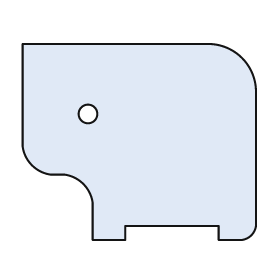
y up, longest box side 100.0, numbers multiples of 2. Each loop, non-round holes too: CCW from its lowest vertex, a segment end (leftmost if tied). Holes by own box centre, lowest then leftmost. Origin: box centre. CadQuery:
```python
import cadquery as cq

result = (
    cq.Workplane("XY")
    .moveTo(-20.0, -42.0)
    .lineTo(-6.0, -42.0)
    .lineTo(-6.0, -36.0)
    .lineTo(34.0, -36.0)
    .lineTo(34.0, -42.0)
    .lineTo(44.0, -42.0)
    .threePointArc((48.0, -40.0), (50.0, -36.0))
    .lineTo(50.0, 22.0)
    .threePointArc((44.0, 36.0), (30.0, 42.0))
    .lineTo(-50.0, 42.0)
    .lineTo(-50.0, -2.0)
    .threePointArc((-46.0, -10.0), (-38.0, -14.0))
    .lineTo(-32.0, -14.0)
    .threePointArc((-24.0, -18.0), (-20.0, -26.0))
    .close()
    .moveTo(-22.0, 12.0)
    .circle(4.0)
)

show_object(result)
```